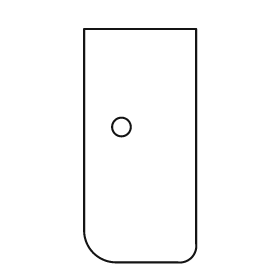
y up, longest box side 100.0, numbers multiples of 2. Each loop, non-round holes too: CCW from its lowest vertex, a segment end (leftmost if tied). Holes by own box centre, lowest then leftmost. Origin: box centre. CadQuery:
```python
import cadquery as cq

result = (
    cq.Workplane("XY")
    .moveTo(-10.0, -50.0)
    .lineTo(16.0, -50.0)
    .threePointArc((22.0, -48.0), (24.0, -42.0))
    .lineTo(24.0, 50.0)
    .lineTo(-24.0, 50.0)
    .lineTo(-24.0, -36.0)
    .threePointArc((-20.0, -46.0), (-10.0, -50.0))
    .close()
    .moveTo(-8.0, 8.0)
    .circle(4.0)
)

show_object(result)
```